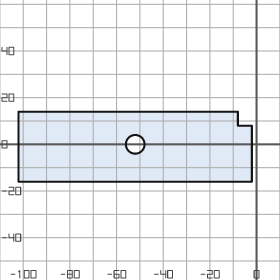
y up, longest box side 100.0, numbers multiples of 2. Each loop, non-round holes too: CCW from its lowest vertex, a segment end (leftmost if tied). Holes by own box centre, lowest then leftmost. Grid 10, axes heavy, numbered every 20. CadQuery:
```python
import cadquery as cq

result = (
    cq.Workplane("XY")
    .moveTo(-102.0, -16.0)
    .lineTo(-2.0, -16.0)
    .lineTo(-2.0, 8.0)
    .lineTo(-8.0, 8.0)
    .lineTo(-8.0, 14.0)
    .lineTo(-102.0, 14.0)
    .close()
    .moveTo(-52.0, 0.0)
    .circle(4.0)
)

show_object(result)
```